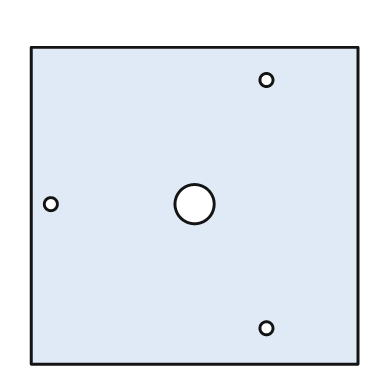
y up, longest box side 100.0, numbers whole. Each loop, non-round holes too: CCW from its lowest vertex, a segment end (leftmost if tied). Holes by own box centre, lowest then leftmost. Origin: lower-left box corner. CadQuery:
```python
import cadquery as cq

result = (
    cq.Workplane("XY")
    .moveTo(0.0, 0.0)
    .lineTo(100.0, 0.0)
    .lineTo(100.0, 97.0)
    .lineTo(0.0, 97.0)
    .close()
    .moveTo(72.0, 11.0)
    .circle(2.0)
    .moveTo(6.0, 49.0)
    .circle(2.0)
    .moveTo(50.0, 49.0)
    .circle(6.0)
    .moveTo(72.0, 87.0)
    .circle(2.0)
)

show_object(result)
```